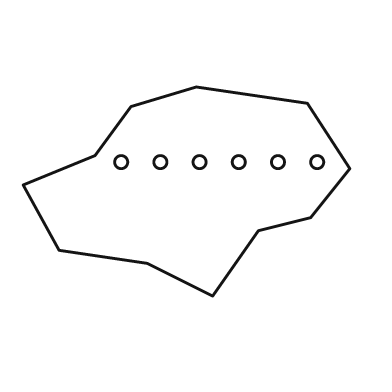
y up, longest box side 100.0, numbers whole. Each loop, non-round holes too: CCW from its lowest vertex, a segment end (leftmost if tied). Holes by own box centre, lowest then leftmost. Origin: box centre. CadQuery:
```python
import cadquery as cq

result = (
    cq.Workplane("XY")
    .moveTo(8.0, -32.0)
    .lineTo(22.0, -12.0)
    .lineTo(38.0, -8.0)
    .lineTo(50.0, 7.0)
    .lineTo(37.0, 27.0)
    .lineTo(3.0, 32.0)
    .lineTo(-17.0, 26.0)
    .lineTo(-28.0, 11.0)
    .lineTo(-50.0, 2.0)
    .lineTo(-39.0, -18.0)
    .lineTo(-12.0, -22.0)
    .close()
    .moveTo(-20.0, 9.0)
    .circle(2.0)
    .moveTo(-8.0, 9.0)
    .circle(2.0)
    .moveTo(4.0, 9.0)
    .circle(2.0)
    .moveTo(16.0, 9.0)
    .circle(2.0)
    .moveTo(28.0, 9.0)
    .circle(2.0)
    .moveTo(40.0, 9.0)
    .circle(2.0)
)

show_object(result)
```